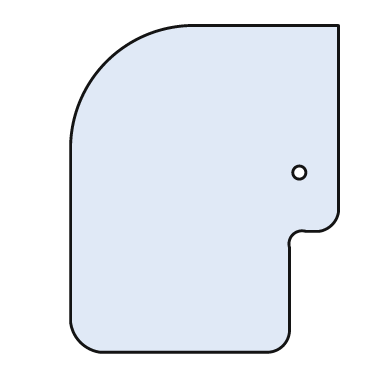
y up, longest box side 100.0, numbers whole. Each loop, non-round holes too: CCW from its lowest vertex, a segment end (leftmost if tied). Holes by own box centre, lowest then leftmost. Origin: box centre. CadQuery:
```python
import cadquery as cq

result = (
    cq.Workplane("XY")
    .moveTo(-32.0, -50.0)
    .lineTo(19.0, -50.0)
    .threePointArc((24.0, -48.0), (26.0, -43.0))
    .lineTo(26.0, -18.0)
    .threePointArc((27.0, -14.0), (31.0, -13.0))
    .lineTo(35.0, -13.0)
    .threePointArc((39.0, -11.0), (41.0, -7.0))
    .lineTo(41.0, 50.0)
    .lineTo(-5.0, 50.0)
    .threePointArc((-30.0, 39.0), (-41.0, 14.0))
    .lineTo(-41.0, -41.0)
    .threePointArc((-38.0, -47.0), (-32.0, -50.0))
    .close()
    .moveTo(29.0, 5.0)
    .circle(2.0)
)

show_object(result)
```